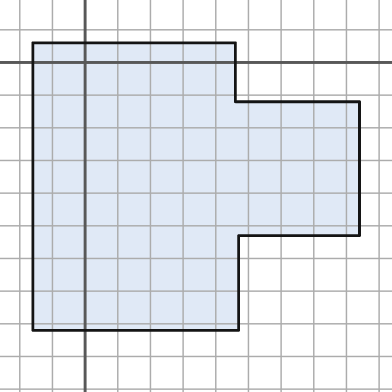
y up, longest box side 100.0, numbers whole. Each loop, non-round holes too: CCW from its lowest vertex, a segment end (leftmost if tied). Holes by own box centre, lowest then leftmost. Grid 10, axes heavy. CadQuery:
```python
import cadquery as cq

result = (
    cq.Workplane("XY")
    .moveTo(-16.0, -82.0)
    .lineTo(47.0, -82.0)
    .lineTo(47.0, -53.0)
    .lineTo(84.0, -53.0)
    .lineTo(84.0, -12.0)
    .lineTo(46.0, -12.0)
    .lineTo(46.0, 6.0)
    .lineTo(-16.0, 6.0)
    .close()
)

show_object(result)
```